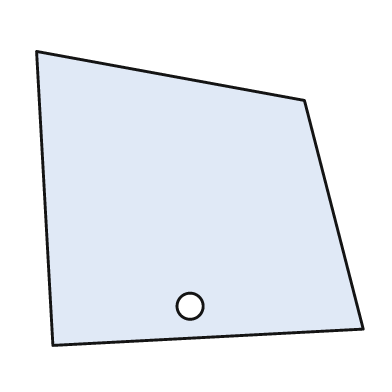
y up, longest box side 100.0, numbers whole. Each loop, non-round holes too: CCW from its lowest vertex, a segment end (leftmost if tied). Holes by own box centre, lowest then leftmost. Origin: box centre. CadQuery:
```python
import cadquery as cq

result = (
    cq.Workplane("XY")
    .moveTo(-45.0, -45.0)
    .lineTo(50.0, -40.0)
    .lineTo(32.0, 30.0)
    .lineTo(-50.0, 45.0)
    .close()
    .moveTo(-3.0, -33.0)
    .circle(4.0)
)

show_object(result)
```